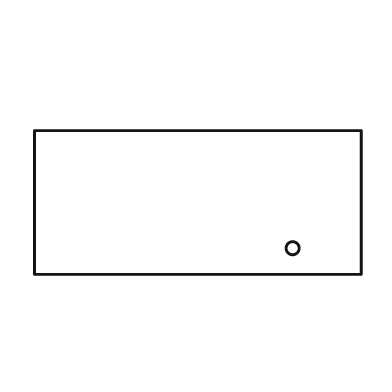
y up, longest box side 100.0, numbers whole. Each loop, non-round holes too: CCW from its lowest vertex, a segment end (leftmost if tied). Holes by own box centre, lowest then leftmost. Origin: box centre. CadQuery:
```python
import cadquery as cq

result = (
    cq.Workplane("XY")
    .moveTo(-50.0, -22.0)
    .lineTo(50.0, -22.0)
    .lineTo(50.0, 22.0)
    .lineTo(-50.0, 22.0)
    .close()
    .moveTo(29.0, -14.0)
    .circle(2.0)
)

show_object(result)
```